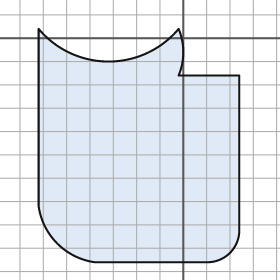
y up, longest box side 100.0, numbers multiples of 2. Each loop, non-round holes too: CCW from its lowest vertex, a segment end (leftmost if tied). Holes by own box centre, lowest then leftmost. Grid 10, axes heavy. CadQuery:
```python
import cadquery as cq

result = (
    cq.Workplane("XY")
    .moveTo(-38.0, -96.0)
    .lineTo(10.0, -96.0)
    .threePointArc((20.0, -92.0), (24.0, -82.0))
    .lineTo(24.0, -16.0)
    .lineTo(-2.0, -16.0)
    .threePointArc((0.0, -6.0), (-2.0, 4.0))
    .threePointArc((-32.0, -10.0), (-62.0, 4.0))
    .lineTo(-62.0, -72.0)
    .threePointArc((-54.0, -88.0), (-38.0, -96.0))
    .close()
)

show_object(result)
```